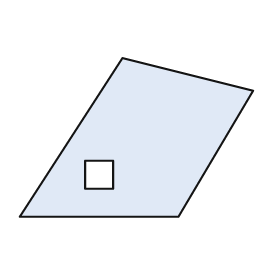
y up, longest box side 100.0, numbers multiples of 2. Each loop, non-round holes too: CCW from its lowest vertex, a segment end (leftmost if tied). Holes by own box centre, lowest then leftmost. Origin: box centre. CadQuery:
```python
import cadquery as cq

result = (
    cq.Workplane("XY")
    .moveTo(-50.0, -34.0)
    .lineTo(18.0, -34.0)
    .lineTo(50.0, 20.0)
    .lineTo(-6.0, 34.0)
    .close()
    .moveTo(-22.0, -22.0)
    .lineTo(-10.0, -22.0)
    .lineTo(-10.0, -10.0)
    .lineTo(-22.0, -10.0)
    .close()
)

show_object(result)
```